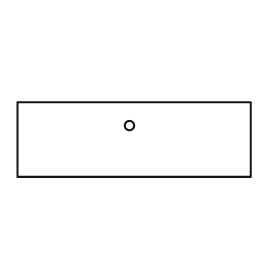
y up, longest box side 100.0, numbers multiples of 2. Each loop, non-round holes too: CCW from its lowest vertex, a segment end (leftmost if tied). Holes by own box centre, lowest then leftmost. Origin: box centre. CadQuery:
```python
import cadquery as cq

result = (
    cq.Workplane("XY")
    .moveTo(-50.0, -16.0)
    .lineTo(50.0, -16.0)
    .lineTo(50.0, 16.0)
    .lineTo(-50.0, 16.0)
    .close()
    .moveTo(-2.0, 6.0)
    .circle(2.0)
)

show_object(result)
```